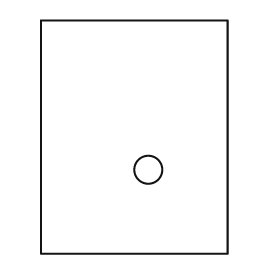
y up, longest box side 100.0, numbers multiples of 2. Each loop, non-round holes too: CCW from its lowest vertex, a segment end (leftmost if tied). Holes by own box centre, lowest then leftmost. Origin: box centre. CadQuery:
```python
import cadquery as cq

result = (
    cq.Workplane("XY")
    .moveTo(-40.0, -50.0)
    .lineTo(40.0, -50.0)
    .lineTo(40.0, 50.0)
    .lineTo(-40.0, 50.0)
    .close()
    .moveTo(6.0, -14.0)
    .circle(6.0)
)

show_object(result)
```